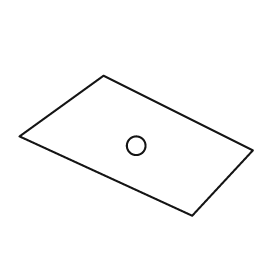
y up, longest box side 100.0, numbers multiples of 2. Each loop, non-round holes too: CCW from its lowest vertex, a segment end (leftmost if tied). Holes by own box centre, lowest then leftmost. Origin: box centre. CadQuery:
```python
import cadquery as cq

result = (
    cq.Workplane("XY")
    .moveTo(24.0, -30.0)
    .lineTo(50.0, -2.0)
    .lineTo(-14.0, 30.0)
    .lineTo(-50.0, 4.0)
    .close()
    .moveTo(0.0, 0.0)
    .circle(4.0)
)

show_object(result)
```